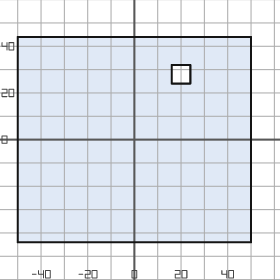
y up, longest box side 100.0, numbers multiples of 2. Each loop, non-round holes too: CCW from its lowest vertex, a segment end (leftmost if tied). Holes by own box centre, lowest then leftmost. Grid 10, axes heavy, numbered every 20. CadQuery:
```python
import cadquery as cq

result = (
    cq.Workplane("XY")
    .moveTo(-50.0, -44.0)
    .lineTo(50.0, -44.0)
    .lineTo(50.0, 44.0)
    .lineTo(-50.0, 44.0)
    .close()
    .moveTo(16.0, 24.0)
    .lineTo(24.0, 24.0)
    .lineTo(24.0, 32.0)
    .lineTo(16.0, 32.0)
    .close()
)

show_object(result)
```